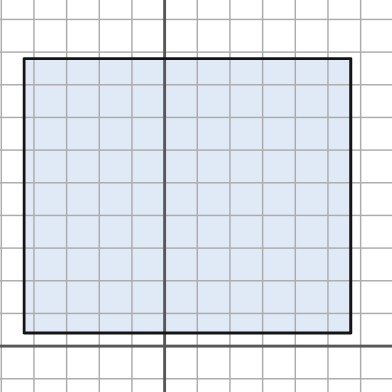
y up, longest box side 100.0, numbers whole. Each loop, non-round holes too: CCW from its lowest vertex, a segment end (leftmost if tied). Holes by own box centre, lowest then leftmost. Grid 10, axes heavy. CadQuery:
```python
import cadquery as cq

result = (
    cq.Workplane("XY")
    .moveTo(-43.0, 4.0)
    .lineTo(57.0, 4.0)
    .lineTo(57.0, 88.0)
    .lineTo(-43.0, 88.0)
    .close()
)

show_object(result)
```